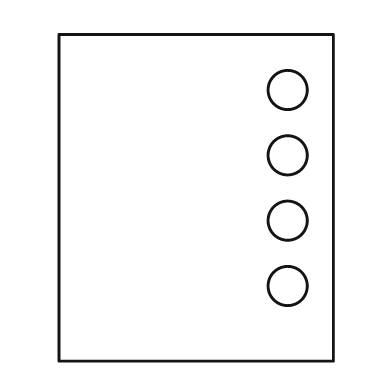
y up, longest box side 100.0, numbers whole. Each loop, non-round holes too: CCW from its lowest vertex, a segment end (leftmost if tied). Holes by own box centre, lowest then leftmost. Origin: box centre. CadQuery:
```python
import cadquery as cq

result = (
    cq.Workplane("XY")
    .moveTo(-42.0, -50.0)
    .lineTo(42.0, -50.0)
    .lineTo(42.0, 50.0)
    .lineTo(-42.0, 50.0)
    .close()
    .moveTo(28.0, -27.0)
    .circle(6.0)
    .moveTo(28.0, -7.0)
    .circle(6.0)
    .moveTo(28.0, 13.0)
    .circle(6.0)
    .moveTo(28.0, 33.0)
    .circle(6.0)
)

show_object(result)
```